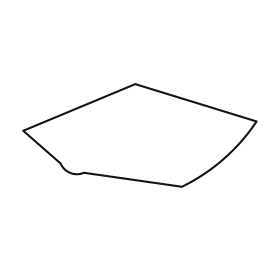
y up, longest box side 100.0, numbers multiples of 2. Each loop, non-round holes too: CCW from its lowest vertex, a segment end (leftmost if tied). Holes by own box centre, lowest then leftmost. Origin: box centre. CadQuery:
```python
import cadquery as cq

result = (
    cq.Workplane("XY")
    .moveTo(18.0, -22.0)
    .threePointArc((36.0, -10.0), (50.0, 6.0))
    .lineTo(-2.0, 22.0)
    .lineTo(-50.0, 2.0)
    .lineTo(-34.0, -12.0)
    .threePointArc((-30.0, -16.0), (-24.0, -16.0))
    .close()
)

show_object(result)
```